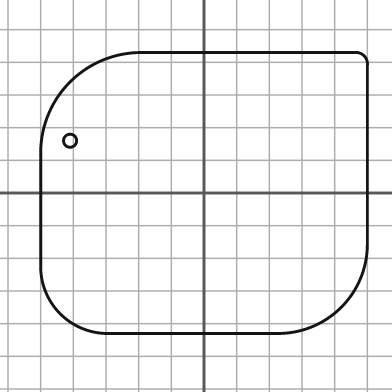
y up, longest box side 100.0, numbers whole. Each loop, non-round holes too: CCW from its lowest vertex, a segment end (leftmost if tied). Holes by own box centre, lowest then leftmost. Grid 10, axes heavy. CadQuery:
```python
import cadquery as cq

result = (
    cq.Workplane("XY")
    .moveTo(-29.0, -43.0)
    .lineTo(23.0, -43.0)
    .threePointArc((42.0, -35.0), (50.0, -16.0))
    .lineTo(50.0, 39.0)
    .threePointArc((49.0, 42.0), (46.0, 43.0))
    .lineTo(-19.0, 43.0)
    .threePointArc((-41.0, 34.0), (-50.0, 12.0))
    .lineTo(-50.0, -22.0)
    .threePointArc((-44.0, -37.0), (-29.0, -43.0))
    .close()
    .moveTo(-41.0, 16.0)
    .circle(2.0)
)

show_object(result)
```